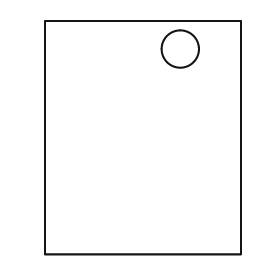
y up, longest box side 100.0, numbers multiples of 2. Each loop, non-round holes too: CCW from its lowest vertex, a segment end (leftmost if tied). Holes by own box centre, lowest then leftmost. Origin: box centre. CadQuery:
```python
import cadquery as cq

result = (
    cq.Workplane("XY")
    .moveTo(-42.0, -50.0)
    .lineTo(42.0, -50.0)
    .lineTo(42.0, 50.0)
    .lineTo(-42.0, 50.0)
    .close()
    .moveTo(16.0, 38.0)
    .circle(8.0)
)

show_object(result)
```